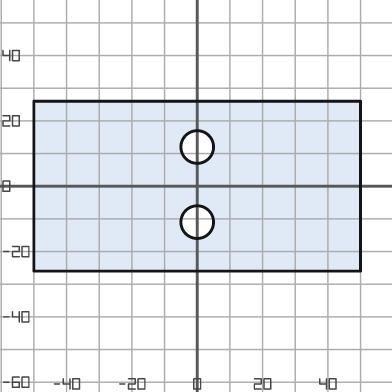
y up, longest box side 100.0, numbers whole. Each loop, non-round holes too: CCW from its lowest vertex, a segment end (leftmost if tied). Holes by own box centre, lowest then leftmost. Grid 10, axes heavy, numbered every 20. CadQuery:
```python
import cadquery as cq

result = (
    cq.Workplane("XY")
    .moveTo(-50.0, -26.0)
    .lineTo(50.0, -26.0)
    .lineTo(50.0, 26.0)
    .lineTo(-50.0, 26.0)
    .close()
    .moveTo(0.0, -11.0)
    .circle(5.0)
    .moveTo(0.0, 12.0)
    .circle(5.0)
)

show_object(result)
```